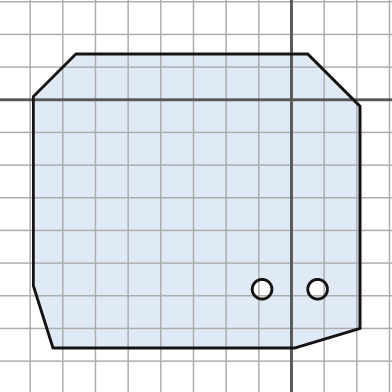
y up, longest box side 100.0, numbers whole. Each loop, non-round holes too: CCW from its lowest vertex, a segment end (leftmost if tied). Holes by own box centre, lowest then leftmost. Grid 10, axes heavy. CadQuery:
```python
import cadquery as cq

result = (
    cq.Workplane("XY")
    .moveTo(-73.0, -76.0)
    .lineTo(1.0, -76.0)
    .lineTo(21.0, -70.0)
    .lineTo(21.0, -2.0)
    .lineTo(5.0, 14.0)
    .lineTo(-66.0, 14.0)
    .lineTo(-79.0, 1.0)
    .lineTo(-79.0, -57.0)
    .close()
    .moveTo(-9.0, -58.0)
    .circle(3.0)
    .moveTo(8.0, -58.0)
    .circle(3.0)
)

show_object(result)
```